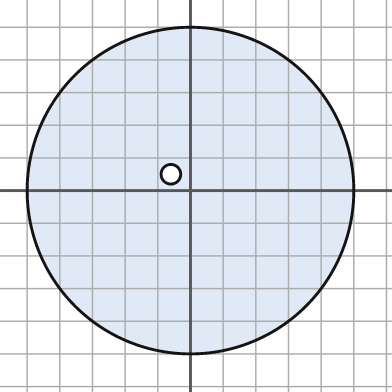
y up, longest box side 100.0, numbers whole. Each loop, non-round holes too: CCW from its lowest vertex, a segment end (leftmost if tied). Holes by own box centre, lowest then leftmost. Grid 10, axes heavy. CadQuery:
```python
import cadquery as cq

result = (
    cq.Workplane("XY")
    .moveTo(0.0, 0.0)
    .circle(50.0)
    .moveTo(-6.0, 5.0)
    .circle(3.0)
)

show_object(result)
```